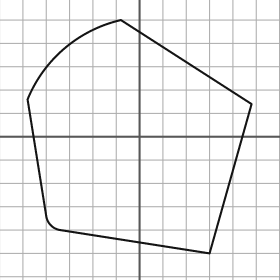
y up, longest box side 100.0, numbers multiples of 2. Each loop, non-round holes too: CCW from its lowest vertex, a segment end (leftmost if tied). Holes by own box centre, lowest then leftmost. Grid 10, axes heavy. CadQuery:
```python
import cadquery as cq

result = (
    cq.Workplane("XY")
    .moveTo(30.0, -50.0)
    .lineTo(48.0, 14.0)
    .lineTo(-8.0, 50.0)
    .threePointArc((-32.0, 38.0), (-48.0, 16.0))
    .lineTo(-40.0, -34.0)
    .threePointArc((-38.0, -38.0), (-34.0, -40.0))
    .close()
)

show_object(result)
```